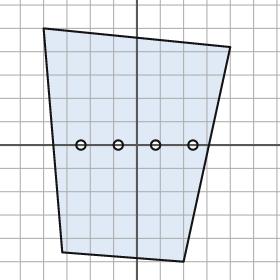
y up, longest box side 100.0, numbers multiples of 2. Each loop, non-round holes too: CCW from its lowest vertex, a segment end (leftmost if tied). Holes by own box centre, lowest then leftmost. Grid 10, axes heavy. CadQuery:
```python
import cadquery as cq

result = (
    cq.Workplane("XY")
    .moveTo(20.0, -50.0)
    .lineTo(40.0, 42.0)
    .lineTo(-40.0, 50.0)
    .lineTo(-32.0, -46.0)
    .close()
    .moveTo(-24.0, 0.0)
    .circle(2.0)
    .moveTo(-8.0, 0.0)
    .circle(2.0)
    .moveTo(8.0, 0.0)
    .circle(2.0)
    .moveTo(24.0, 0.0)
    .circle(2.0)
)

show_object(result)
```